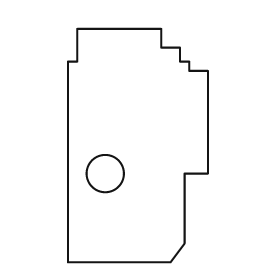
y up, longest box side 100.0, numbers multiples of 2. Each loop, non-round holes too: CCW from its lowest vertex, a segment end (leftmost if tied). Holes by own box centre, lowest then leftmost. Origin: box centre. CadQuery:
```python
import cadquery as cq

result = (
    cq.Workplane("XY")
    .moveTo(-30.0, -50.0)
    .lineTo(14.0, -50.0)
    .lineTo(20.0, -42.0)
    .lineTo(20.0, -12.0)
    .lineTo(30.0, -12.0)
    .lineTo(30.0, 32.0)
    .lineTo(22.0, 32.0)
    .lineTo(22.0, 36.0)
    .lineTo(18.0, 36.0)
    .lineTo(18.0, 42.0)
    .lineTo(10.0, 42.0)
    .lineTo(10.0, 50.0)
    .lineTo(-26.0, 50.0)
    .lineTo(-26.0, 36.0)
    .lineTo(-30.0, 36.0)
    .close()
    .moveTo(-14.0, -12.0)
    .circle(8.0)
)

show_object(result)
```